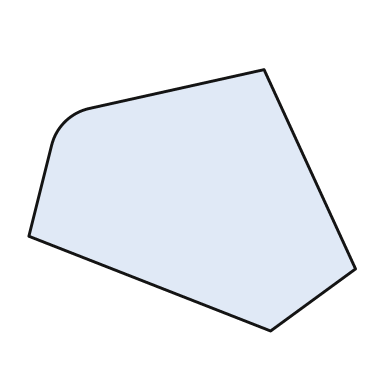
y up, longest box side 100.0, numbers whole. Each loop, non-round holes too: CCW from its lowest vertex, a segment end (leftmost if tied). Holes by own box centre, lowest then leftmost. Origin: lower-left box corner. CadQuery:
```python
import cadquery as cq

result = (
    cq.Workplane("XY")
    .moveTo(74.0, 0.0)
    .lineTo(100.0, 19.0)
    .lineTo(72.0, 80.0)
    .lineTo(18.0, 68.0)
    .threePointArc((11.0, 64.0), (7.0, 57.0))
    .lineTo(0.0, 29.0)
    .close()
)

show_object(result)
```